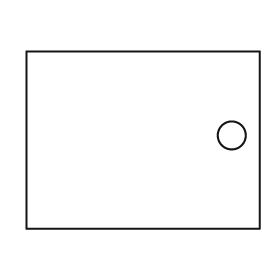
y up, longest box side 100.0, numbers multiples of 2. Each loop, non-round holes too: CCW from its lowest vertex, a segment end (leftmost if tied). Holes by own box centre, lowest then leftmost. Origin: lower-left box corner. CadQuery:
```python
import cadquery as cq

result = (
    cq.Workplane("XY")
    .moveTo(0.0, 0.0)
    .lineTo(100.0, 0.0)
    .lineTo(100.0, 76.0)
    .lineTo(0.0, 76.0)
    .close()
    .moveTo(88.0, 40.0)
    .circle(6.0)
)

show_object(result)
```